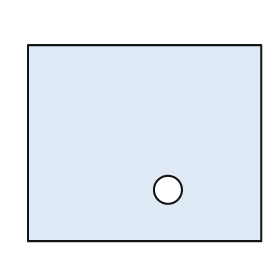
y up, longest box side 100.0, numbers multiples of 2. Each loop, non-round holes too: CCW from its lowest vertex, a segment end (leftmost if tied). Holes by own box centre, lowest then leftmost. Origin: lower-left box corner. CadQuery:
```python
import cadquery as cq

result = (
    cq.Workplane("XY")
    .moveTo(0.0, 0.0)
    .lineTo(100.0, 0.0)
    .lineTo(100.0, 84.0)
    .lineTo(0.0, 84.0)
    .close()
    .moveTo(60.0, 22.0)
    .circle(6.0)
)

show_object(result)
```